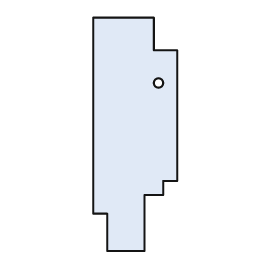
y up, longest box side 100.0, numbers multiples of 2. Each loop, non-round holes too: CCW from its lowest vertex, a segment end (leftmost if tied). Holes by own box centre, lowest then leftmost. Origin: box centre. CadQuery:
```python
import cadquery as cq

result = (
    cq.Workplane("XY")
    .moveTo(-12.0, -50.0)
    .lineTo(4.0, -50.0)
    .lineTo(4.0, -26.0)
    .lineTo(12.0, -26.0)
    .lineTo(12.0, -20.0)
    .lineTo(18.0, -20.0)
    .lineTo(18.0, 36.0)
    .lineTo(8.0, 36.0)
    .lineTo(8.0, 50.0)
    .lineTo(-18.0, 50.0)
    .lineTo(-18.0, -34.0)
    .lineTo(-12.0, -34.0)
    .close()
    .moveTo(10.0, 22.0)
    .circle(2.0)
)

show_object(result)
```